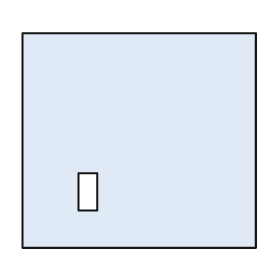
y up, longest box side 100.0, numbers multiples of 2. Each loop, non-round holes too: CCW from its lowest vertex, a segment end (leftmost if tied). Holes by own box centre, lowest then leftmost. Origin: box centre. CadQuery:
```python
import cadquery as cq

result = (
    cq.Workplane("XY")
    .moveTo(-50.0, -46.0)
    .lineTo(50.0, -46.0)
    .lineTo(50.0, 46.0)
    .lineTo(-50.0, 46.0)
    .close()
    .moveTo(-26.0, -30.0)
    .lineTo(-18.0, -30.0)
    .lineTo(-18.0, -14.0)
    .lineTo(-26.0, -14.0)
    .close()
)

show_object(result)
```